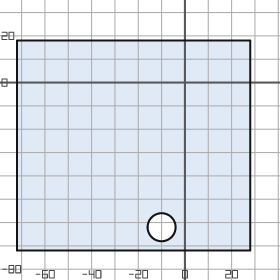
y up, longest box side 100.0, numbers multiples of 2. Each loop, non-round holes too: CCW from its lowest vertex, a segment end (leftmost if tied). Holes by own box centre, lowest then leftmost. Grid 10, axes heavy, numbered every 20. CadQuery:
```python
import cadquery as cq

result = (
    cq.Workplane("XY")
    .moveTo(-72.0, -72.0)
    .lineTo(28.0, -72.0)
    .lineTo(28.0, 18.0)
    .lineTo(-72.0, 18.0)
    .close()
    .moveTo(-10.0, -62.0)
    .circle(6.0)
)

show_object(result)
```